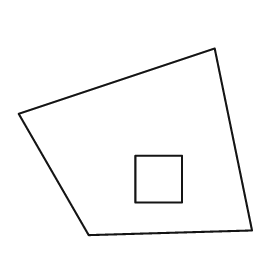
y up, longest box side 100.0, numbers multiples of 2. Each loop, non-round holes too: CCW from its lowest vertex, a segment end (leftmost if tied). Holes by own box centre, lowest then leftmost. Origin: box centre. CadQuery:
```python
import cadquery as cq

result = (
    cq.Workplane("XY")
    .moveTo(-20.0, -40.0)
    .lineTo(50.0, -38.0)
    .lineTo(34.0, 40.0)
    .lineTo(-50.0, 12.0)
    .close()
    .moveTo(0.0, -26.0)
    .lineTo(20.0, -26.0)
    .lineTo(20.0, -6.0)
    .lineTo(0.0, -6.0)
    .close()
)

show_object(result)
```